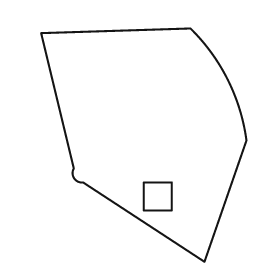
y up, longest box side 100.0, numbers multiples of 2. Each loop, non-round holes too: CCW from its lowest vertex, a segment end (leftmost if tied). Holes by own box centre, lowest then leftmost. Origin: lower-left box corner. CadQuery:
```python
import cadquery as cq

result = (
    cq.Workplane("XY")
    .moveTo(70.0, 0.0)
    .lineTo(88.0, 52.0)
    .threePointArc((80.0, 78.0), (64.0, 100.0))
    .lineTo(0.0, 98.0)
    .lineTo(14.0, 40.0)
    .threePointArc((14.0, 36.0), (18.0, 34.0))
    .close()
    .moveTo(44.0, 22.0)
    .lineTo(56.0, 22.0)
    .lineTo(56.0, 34.0)
    .lineTo(44.0, 34.0)
    .close()
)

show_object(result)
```